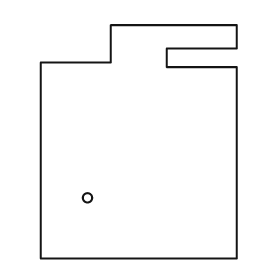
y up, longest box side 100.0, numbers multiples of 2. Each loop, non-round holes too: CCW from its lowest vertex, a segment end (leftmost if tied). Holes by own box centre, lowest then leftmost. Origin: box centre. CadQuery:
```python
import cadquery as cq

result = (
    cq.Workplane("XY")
    .moveTo(-42.0, -50.0)
    .lineTo(42.0, -50.0)
    .lineTo(42.0, 32.0)
    .lineTo(12.0, 32.0)
    .lineTo(12.0, 40.0)
    .lineTo(42.0, 40.0)
    .lineTo(42.0, 50.0)
    .lineTo(-12.0, 50.0)
    .lineTo(-12.0, 34.0)
    .lineTo(-42.0, 34.0)
    .close()
    .moveTo(-22.0, -24.0)
    .circle(2.0)
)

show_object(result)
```